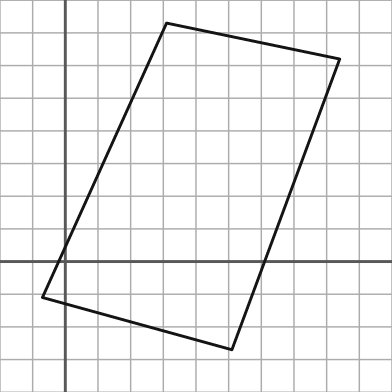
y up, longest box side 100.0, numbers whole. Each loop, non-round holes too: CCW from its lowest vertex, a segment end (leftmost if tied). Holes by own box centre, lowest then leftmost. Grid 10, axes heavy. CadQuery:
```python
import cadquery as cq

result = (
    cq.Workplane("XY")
    .moveTo(51.0, -27.0)
    .lineTo(84.0, 62.0)
    .lineTo(31.0, 73.0)
    .lineTo(-7.0, -11.0)
    .close()
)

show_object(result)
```